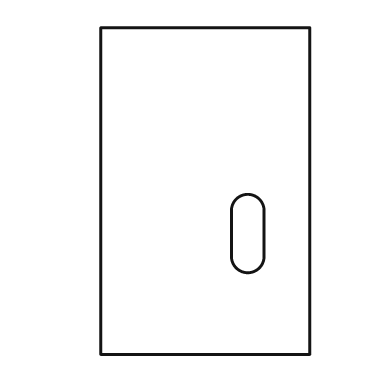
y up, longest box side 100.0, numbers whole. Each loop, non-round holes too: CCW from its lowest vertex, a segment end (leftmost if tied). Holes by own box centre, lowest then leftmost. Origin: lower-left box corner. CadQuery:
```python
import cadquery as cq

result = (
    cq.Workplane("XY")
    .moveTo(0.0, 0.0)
    .lineTo(64.0, 0.0)
    .lineTo(64.0, 100.0)
    .lineTo(0.0, 100.0)
    .close()
    .moveTo(40.0, 30.0)
    .threePointArc((45.0, 25.0), (50.0, 30.0))
    .lineTo(50.0, 44.0)
    .threePointArc((45.0, 49.0), (40.0, 44.0))
    .close()
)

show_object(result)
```